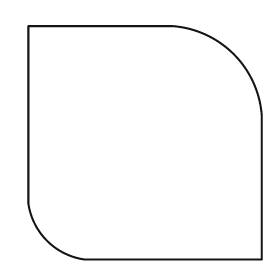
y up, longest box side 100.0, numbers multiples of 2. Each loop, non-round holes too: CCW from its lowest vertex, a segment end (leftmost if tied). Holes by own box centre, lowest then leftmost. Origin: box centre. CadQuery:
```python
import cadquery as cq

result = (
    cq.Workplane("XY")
    .moveTo(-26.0, -50.0)
    .lineTo(50.0, -50.0)
    .lineTo(50.0, 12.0)
    .threePointArc((38.0, 38.0), (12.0, 50.0))
    .lineTo(-50.0, 50.0)
    .lineTo(-50.0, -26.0)
    .threePointArc((-42.0, -42.0), (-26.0, -50.0))
    .close()
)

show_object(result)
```